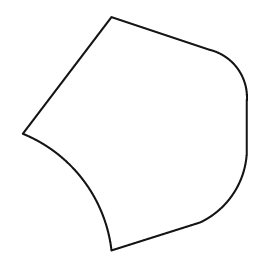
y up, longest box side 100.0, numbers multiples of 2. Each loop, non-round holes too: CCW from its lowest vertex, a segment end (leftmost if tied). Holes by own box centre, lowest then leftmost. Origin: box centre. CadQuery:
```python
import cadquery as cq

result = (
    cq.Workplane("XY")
    .moveTo(-10.0, -50.0)
    .lineTo(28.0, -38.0)
    .threePointArc((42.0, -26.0), (48.0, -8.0))
    .lineTo(48.0, 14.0)
    .threePointArc((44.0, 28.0), (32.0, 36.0))
    .lineTo(-10.0, 50.0)
    .lineTo(-48.0, 0.0)
    .threePointArc((-22.0, -20.0), (-10.0, -50.0))
    .close()
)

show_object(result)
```